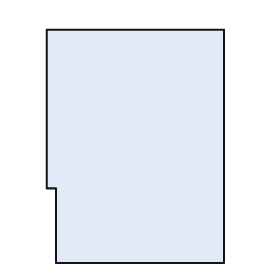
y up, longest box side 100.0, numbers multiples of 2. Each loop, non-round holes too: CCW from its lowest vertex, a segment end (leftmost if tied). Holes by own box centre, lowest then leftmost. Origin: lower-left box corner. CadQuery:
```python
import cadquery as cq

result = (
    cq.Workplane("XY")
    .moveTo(4.0, 0.0)
    .lineTo(76.0, 0.0)
    .lineTo(76.0, 100.0)
    .lineTo(0.0, 100.0)
    .lineTo(0.0, 32.0)
    .lineTo(4.0, 32.0)
    .close()
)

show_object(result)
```